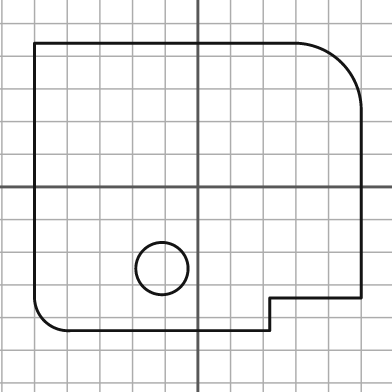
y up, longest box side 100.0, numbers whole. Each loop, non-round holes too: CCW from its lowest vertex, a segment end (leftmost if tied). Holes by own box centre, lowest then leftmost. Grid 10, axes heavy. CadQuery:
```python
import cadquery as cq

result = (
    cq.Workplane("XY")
    .moveTo(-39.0, -44.0)
    .lineTo(22.0, -44.0)
    .lineTo(22.0, -34.0)
    .lineTo(50.0, -34.0)
    .lineTo(50.0, 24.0)
    .threePointArc((44.0, 38.0), (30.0, 44.0))
    .lineTo(-50.0, 44.0)
    .lineTo(-50.0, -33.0)
    .threePointArc((-47.0, -41.0), (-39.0, -44.0))
    .close()
    .moveTo(-11.0, -25.0)
    .circle(8.0)
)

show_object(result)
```